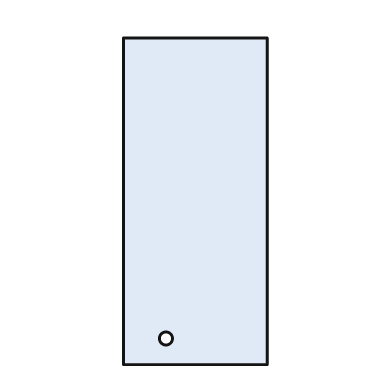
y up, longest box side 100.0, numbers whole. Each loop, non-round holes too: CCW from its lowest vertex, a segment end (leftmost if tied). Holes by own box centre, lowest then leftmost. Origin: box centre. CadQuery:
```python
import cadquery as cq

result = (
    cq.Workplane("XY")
    .moveTo(-22.0, -50.0)
    .lineTo(22.0, -50.0)
    .lineTo(22.0, 50.0)
    .lineTo(-22.0, 50.0)
    .close()
    .moveTo(-9.0, -42.0)
    .circle(2.0)
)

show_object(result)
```